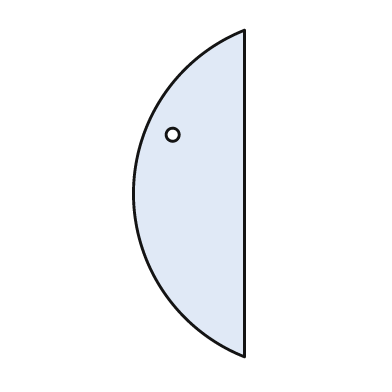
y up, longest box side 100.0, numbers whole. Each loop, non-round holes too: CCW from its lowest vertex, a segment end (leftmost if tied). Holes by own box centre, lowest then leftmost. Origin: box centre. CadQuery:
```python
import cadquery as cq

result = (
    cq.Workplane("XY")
    .moveTo(17.0, -50.0)
    .lineTo(17.0, 50.0)
    .threePointArc((-17.0, 0.0), (17.0, -50.0))
    .close()
    .moveTo(-5.0, 18.0)
    .circle(2.0)
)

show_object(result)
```